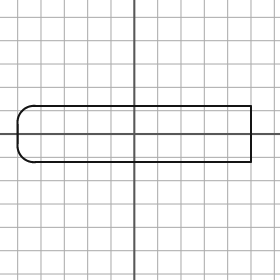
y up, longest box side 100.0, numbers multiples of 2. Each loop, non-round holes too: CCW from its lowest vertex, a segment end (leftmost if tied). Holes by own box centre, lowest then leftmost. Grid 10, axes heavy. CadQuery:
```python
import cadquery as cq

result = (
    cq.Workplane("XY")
    .moveTo(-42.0, -12.0)
    .lineTo(50.0, -12.0)
    .lineTo(50.0, 12.0)
    .lineTo(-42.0, 12.0)
    .threePointArc((-48.0, 10.0), (-50.0, 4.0))
    .lineTo(-50.0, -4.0)
    .threePointArc((-48.0, -10.0), (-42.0, -12.0))
    .close()
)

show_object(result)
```